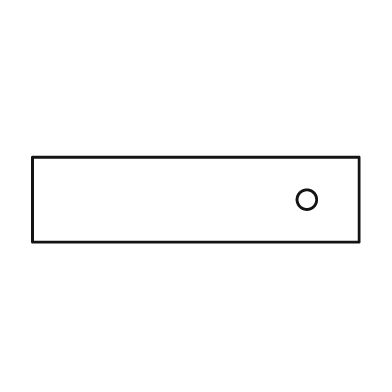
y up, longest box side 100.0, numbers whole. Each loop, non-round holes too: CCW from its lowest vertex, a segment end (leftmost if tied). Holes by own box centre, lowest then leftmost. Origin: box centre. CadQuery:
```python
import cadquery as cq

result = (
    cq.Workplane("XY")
    .moveTo(-50.0, -13.0)
    .lineTo(50.0, -13.0)
    .lineTo(50.0, 13.0)
    .lineTo(-50.0, 13.0)
    .close()
    .moveTo(34.0, 0.0)
    .circle(3.0)
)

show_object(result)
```